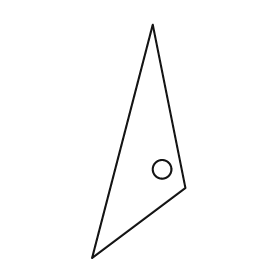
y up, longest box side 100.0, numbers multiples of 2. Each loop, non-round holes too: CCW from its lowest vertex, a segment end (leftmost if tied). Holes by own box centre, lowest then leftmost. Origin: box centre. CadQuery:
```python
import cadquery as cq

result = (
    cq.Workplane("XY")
    .moveTo(-20.0, -50.0)
    .lineTo(20.0, -20.0)
    .lineTo(6.0, 50.0)
    .close()
    .moveTo(10.0, -12.0)
    .circle(4.0)
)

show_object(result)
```